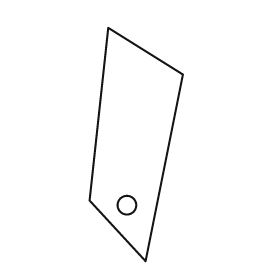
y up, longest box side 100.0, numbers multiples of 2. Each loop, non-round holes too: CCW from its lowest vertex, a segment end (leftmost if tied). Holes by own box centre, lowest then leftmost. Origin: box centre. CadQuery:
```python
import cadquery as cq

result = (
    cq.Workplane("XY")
    .moveTo(4.0, -50.0)
    .lineTo(20.0, 30.0)
    .lineTo(-12.0, 50.0)
    .lineTo(-20.0, -24.0)
    .close()
    .moveTo(-4.0, -26.0)
    .circle(4.0)
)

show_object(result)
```